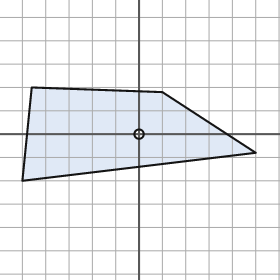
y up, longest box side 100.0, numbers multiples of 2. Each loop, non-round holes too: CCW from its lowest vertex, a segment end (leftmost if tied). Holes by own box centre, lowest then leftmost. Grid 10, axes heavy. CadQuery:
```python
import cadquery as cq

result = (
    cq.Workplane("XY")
    .moveTo(-50.0, -20.0)
    .lineTo(50.0, -8.0)
    .lineTo(10.0, 18.0)
    .lineTo(-46.0, 20.0)
    .close()
    .moveTo(0.0, 0.0)
    .circle(2.0)
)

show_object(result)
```